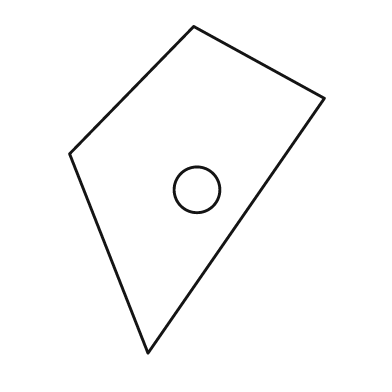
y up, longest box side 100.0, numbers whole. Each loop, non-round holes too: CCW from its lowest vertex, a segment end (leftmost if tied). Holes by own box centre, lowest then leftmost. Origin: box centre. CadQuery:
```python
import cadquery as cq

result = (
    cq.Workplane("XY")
    .moveTo(-15.0, -50.0)
    .lineTo(39.0, 28.0)
    .lineTo(-1.0, 50.0)
    .lineTo(-39.0, 11.0)
    .close()
    .moveTo(0.0, 0.0)
    .circle(7.0)
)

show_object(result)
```